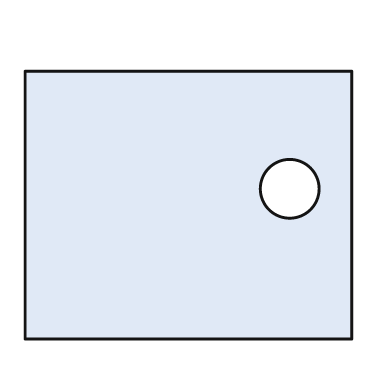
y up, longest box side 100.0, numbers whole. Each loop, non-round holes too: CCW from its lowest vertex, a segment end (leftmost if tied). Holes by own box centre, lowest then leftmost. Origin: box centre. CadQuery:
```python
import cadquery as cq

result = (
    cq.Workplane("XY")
    .moveTo(-50.0, -41.0)
    .lineTo(50.0, -41.0)
    .lineTo(50.0, 41.0)
    .lineTo(-50.0, 41.0)
    .close()
    .moveTo(31.0, 5.0)
    .circle(9.0)
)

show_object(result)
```